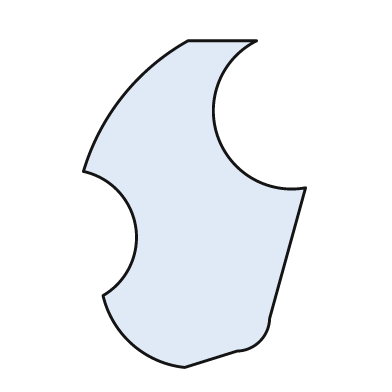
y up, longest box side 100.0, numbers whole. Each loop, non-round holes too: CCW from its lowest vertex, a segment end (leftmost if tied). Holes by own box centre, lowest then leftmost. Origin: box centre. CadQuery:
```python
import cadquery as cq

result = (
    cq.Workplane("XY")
    .moveTo(-3.0, -50.0)
    .lineTo(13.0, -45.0)
    .threePointArc((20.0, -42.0), (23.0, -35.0))
    .lineTo(34.0, 5.0)
    .threePointArc((7.0, 21.0), (19.0, 50.0))
    .lineTo(-2.0, 50.0)
    .threePointArc((-22.0, 33.0), (-34.0, 10.0))
    .threePointArc((-18.0, -7.0), (-28.0, -28.0))
    .threePointArc((-19.0, -43.0), (-3.0, -50.0))
    .close()
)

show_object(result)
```